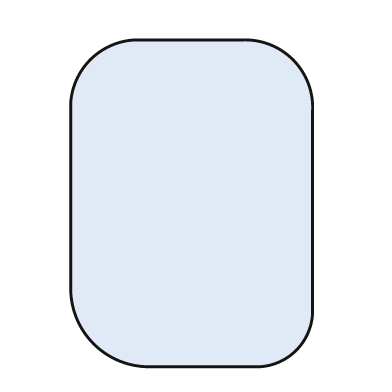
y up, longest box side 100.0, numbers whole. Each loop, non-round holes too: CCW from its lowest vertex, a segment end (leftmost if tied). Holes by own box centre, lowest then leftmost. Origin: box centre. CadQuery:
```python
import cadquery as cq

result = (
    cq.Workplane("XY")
    .moveTo(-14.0, -50.0)
    .lineTo(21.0, -50.0)
    .threePointArc((32.0, -45.0), (37.0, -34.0))
    .lineTo(37.0, 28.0)
    .threePointArc((31.0, 44.0), (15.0, 50.0))
    .lineTo(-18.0, 50.0)
    .threePointArc((-31.0, 44.0), (-37.0, 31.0))
    .lineTo(-37.0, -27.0)
    .threePointArc((-30.0, -43.0), (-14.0, -50.0))
    .close()
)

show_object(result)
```